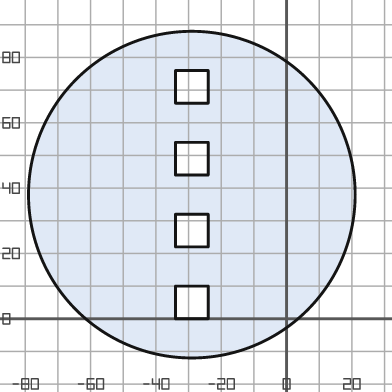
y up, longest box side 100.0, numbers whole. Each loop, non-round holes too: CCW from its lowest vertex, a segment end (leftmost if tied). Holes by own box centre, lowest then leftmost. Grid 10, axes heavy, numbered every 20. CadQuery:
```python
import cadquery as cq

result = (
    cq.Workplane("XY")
    .moveTo(-29.0, 38.0)
    .circle(50.0)
    .moveTo(-34.0, 0.0)
    .lineTo(-24.0, 0.0)
    .lineTo(-24.0, 10.0)
    .lineTo(-34.0, 10.0)
    .close()
    .moveTo(-34.0, 22.0)
    .lineTo(-24.0, 22.0)
    .lineTo(-24.0, 32.0)
    .lineTo(-34.0, 32.0)
    .close()
    .moveTo(-34.0, 44.0)
    .lineTo(-24.0, 44.0)
    .lineTo(-24.0, 54.0)
    .lineTo(-34.0, 54.0)
    .close()
    .moveTo(-34.0, 66.0)
    .lineTo(-24.0, 66.0)
    .lineTo(-24.0, 76.0)
    .lineTo(-34.0, 76.0)
    .close()
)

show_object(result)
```